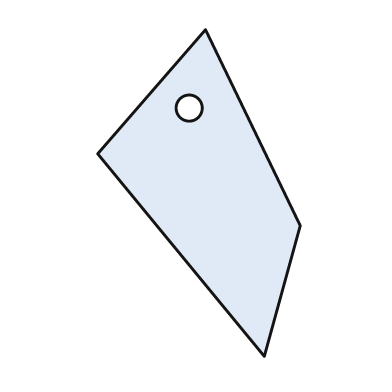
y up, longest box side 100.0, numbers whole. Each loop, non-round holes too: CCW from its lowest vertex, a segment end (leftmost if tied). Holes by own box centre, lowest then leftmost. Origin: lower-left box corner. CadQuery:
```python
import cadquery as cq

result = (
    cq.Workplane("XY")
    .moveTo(51.0, 0.0)
    .lineTo(62.0, 40.0)
    .lineTo(33.0, 100.0)
    .lineTo(0.0, 62.0)
    .close()
    .moveTo(28.0, 76.0)
    .circle(4.0)
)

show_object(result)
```